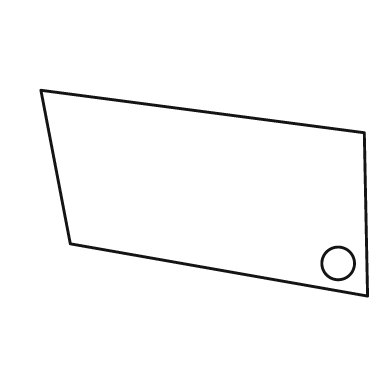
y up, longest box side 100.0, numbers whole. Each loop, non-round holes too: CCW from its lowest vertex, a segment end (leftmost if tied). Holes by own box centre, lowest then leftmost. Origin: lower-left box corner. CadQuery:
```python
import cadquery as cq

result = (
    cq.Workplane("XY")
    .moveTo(100.0, 0.0)
    .lineTo(99.0, 50.0)
    .lineTo(0.0, 63.0)
    .lineTo(9.0, 16.0)
    .close()
    .moveTo(91.0, 10.0)
    .circle(5.0)
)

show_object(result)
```